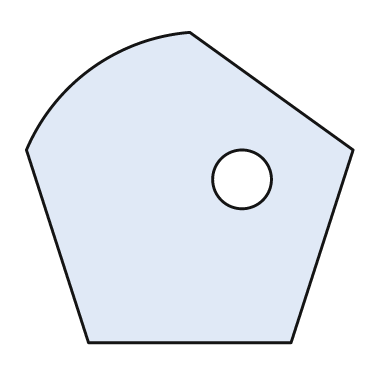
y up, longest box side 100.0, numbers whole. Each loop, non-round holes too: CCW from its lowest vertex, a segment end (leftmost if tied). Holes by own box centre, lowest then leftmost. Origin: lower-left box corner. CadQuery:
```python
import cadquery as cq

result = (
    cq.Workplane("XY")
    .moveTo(19.0, 0.0)
    .lineTo(81.0, 0.0)
    .lineTo(100.0, 59.0)
    .lineTo(50.0, 95.0)
    .threePointArc((20.0, 84.0), (0.0, 59.0))
    .close()
    .moveTo(66.0, 50.0)
    .circle(9.0)
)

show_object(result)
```